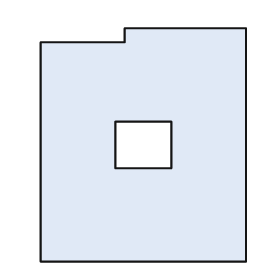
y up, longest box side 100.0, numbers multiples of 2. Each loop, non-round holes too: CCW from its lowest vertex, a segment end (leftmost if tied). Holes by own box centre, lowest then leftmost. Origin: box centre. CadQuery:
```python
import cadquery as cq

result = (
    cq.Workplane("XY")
    .moveTo(-44.0, -50.0)
    .lineTo(44.0, -50.0)
    .lineTo(44.0, 50.0)
    .lineTo(-8.0, 50.0)
    .lineTo(-8.0, 44.0)
    .lineTo(-44.0, 44.0)
    .close()
    .moveTo(-12.0, -10.0)
    .lineTo(12.0, -10.0)
    .lineTo(12.0, 10.0)
    .lineTo(-12.0, 10.0)
    .close()
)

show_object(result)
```